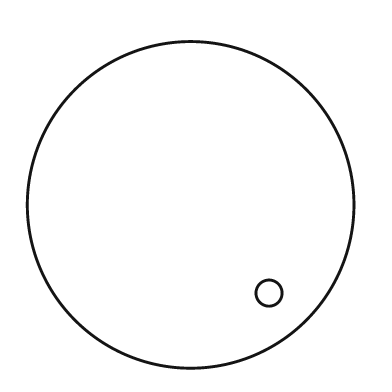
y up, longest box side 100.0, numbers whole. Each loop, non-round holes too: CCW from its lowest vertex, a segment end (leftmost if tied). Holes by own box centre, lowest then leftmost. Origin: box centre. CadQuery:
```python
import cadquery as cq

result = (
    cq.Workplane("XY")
    .moveTo(0.0, 0.0)
    .circle(50.0)
    .moveTo(24.0, -27.0)
    .circle(4.0)
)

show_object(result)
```